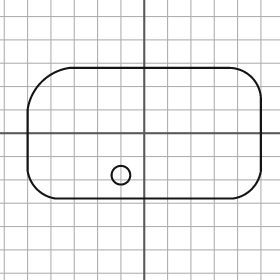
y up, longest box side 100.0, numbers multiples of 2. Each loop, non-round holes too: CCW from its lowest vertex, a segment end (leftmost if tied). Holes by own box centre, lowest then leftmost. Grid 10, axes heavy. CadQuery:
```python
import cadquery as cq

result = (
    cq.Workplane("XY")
    .moveTo(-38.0, -28.0)
    .lineTo(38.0, -28.0)
    .threePointArc((46.0, -24.0), (50.0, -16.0))
    .lineTo(50.0, 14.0)
    .threePointArc((46.0, 24.0), (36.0, 28.0))
    .lineTo(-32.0, 28.0)
    .threePointArc((-44.0, 22.0), (-50.0, 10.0))
    .lineTo(-50.0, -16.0)
    .threePointArc((-46.0, -24.0), (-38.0, -28.0))
    .close()
    .moveTo(-10.0, -18.0)
    .circle(4.0)
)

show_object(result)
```